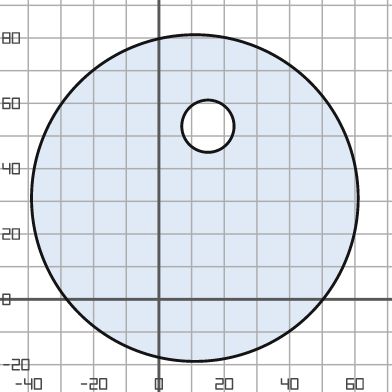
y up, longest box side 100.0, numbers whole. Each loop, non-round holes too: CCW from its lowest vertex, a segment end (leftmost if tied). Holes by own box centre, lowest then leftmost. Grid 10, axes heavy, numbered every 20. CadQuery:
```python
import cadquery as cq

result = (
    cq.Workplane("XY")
    .moveTo(11.0, 31.0)
    .circle(50.0)
    .moveTo(15.0, 53.0)
    .circle(8.0)
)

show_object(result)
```